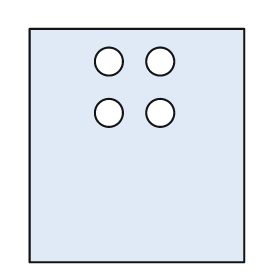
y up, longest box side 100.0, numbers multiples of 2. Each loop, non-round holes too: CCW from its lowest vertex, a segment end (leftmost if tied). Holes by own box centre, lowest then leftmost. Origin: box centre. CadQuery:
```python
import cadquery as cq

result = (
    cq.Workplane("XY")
    .moveTo(-46.0, -50.0)
    .lineTo(46.0, -50.0)
    .lineTo(46.0, 50.0)
    .lineTo(-46.0, 50.0)
    .close()
    .moveTo(-12.0, 14.0)
    .circle(6.0)
    .moveTo(10.0, 14.0)
    .circle(6.0)
    .moveTo(-12.0, 36.0)
    .circle(6.0)
    .moveTo(10.0, 36.0)
    .circle(6.0)
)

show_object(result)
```